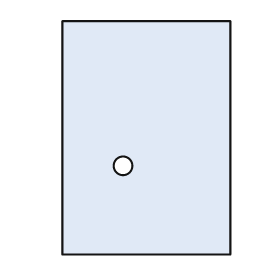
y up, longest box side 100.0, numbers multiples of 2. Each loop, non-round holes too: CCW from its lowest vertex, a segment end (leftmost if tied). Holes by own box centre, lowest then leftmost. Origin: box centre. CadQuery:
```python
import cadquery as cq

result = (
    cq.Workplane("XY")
    .moveTo(-36.0, -50.0)
    .lineTo(36.0, -50.0)
    .lineTo(36.0, 50.0)
    .lineTo(-36.0, 50.0)
    .close()
    .moveTo(-10.0, -12.0)
    .circle(4.0)
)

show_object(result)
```